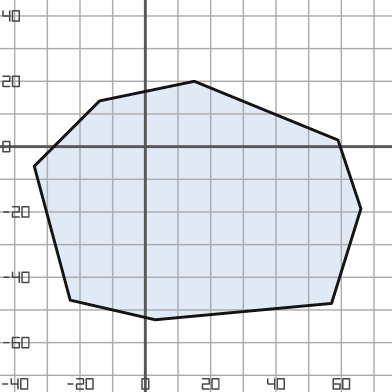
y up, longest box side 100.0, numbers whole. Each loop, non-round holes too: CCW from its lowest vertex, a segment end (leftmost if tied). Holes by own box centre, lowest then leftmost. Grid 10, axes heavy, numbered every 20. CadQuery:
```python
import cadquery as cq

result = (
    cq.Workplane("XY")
    .moveTo(3.0, -53.0)
    .lineTo(57.0, -48.0)
    .lineTo(66.0, -19.0)
    .lineTo(59.0, 2.0)
    .lineTo(15.0, 20.0)
    .lineTo(-14.0, 14.0)
    .lineTo(-34.0, -6.0)
    .lineTo(-23.0, -47.0)
    .close()
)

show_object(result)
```